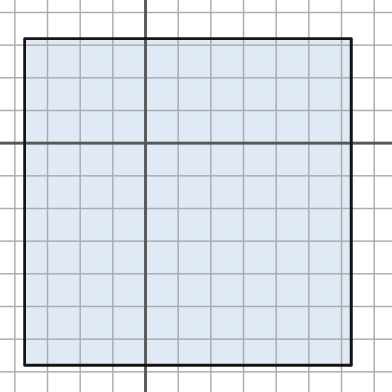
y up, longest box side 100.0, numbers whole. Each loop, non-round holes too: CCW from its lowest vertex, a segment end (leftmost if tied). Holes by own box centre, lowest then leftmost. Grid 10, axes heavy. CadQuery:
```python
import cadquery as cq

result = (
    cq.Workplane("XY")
    .moveTo(-37.0, -68.0)
    .lineTo(63.0, -68.0)
    .lineTo(63.0, 32.0)
    .lineTo(-37.0, 32.0)
    .close()
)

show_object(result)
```